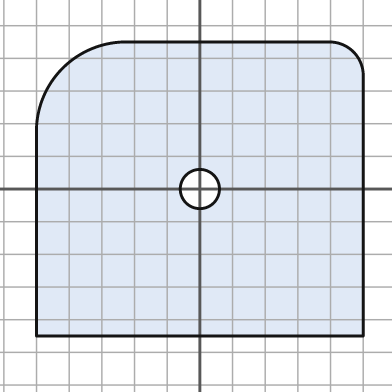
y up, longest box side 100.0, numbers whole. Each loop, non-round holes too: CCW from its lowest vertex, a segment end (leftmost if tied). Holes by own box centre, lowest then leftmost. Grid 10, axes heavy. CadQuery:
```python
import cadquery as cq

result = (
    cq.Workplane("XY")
    .moveTo(-50.0, -45.0)
    .lineTo(50.0, -45.0)
    .lineTo(50.0, 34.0)
    .threePointArc((47.0, 42.0), (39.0, 45.0))
    .lineTo(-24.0, 45.0)
    .threePointArc((-42.0, 37.0), (-50.0, 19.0))
    .close()
    .moveTo(0.0, 0.0)
    .circle(6.0)
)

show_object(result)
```